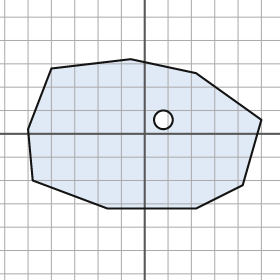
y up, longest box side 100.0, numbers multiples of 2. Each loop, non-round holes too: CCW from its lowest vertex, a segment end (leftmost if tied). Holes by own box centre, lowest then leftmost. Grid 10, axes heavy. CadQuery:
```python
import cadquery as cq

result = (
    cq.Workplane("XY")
    .moveTo(-16.0, -32.0)
    .lineTo(22.0, -32.0)
    .lineTo(42.0, -22.0)
    .lineTo(50.0, 6.0)
    .lineTo(22.0, 26.0)
    .lineTo(-6.0, 32.0)
    .lineTo(-40.0, 28.0)
    .lineTo(-50.0, 2.0)
    .lineTo(-48.0, -20.0)
    .close()
    .moveTo(8.0, 6.0)
    .circle(4.0)
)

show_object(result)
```